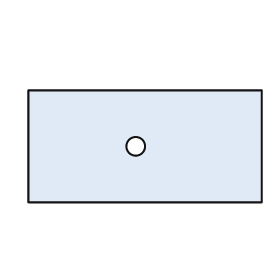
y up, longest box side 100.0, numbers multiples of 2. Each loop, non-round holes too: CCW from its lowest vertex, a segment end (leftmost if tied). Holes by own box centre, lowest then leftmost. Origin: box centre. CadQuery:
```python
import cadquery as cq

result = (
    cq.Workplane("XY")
    .moveTo(-50.0, -24.0)
    .lineTo(50.0, -24.0)
    .lineTo(50.0, 24.0)
    .lineTo(-50.0, 24.0)
    .close()
    .moveTo(-4.0, 0.0)
    .circle(4.0)
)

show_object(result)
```